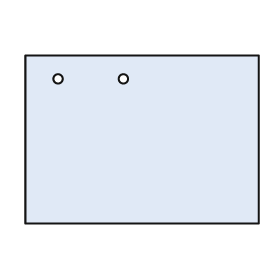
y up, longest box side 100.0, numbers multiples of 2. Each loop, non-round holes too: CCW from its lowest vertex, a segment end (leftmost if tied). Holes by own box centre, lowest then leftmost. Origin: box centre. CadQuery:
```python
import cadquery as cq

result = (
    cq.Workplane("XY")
    .moveTo(-50.0, -36.0)
    .lineTo(50.0, -36.0)
    .lineTo(50.0, 36.0)
    .lineTo(-50.0, 36.0)
    .close()
    .moveTo(-36.0, 26.0)
    .circle(2.0)
    .moveTo(-8.0, 26.0)
    .circle(2.0)
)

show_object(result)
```